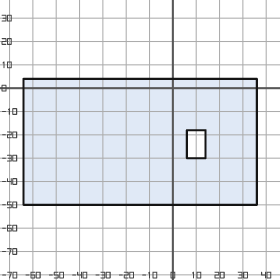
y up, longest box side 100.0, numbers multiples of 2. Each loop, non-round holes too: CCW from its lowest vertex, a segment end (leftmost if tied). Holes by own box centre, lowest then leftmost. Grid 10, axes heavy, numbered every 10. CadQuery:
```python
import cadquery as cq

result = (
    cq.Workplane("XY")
    .moveTo(-64.0, -50.0)
    .lineTo(36.0, -50.0)
    .lineTo(36.0, 4.0)
    .lineTo(-64.0, 4.0)
    .close()
    .moveTo(6.0, -30.0)
    .lineTo(14.0, -30.0)
    .lineTo(14.0, -18.0)
    .lineTo(6.0, -18.0)
    .close()
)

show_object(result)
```